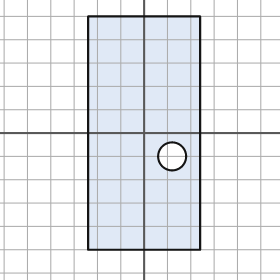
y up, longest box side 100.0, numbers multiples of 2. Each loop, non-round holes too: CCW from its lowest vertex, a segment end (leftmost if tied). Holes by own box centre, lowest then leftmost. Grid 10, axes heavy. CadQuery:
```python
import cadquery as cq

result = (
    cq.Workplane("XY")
    .moveTo(-24.0, -50.0)
    .lineTo(24.0, -50.0)
    .lineTo(24.0, 50.0)
    .lineTo(-24.0, 50.0)
    .close()
    .moveTo(12.0, -10.0)
    .circle(6.0)
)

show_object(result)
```